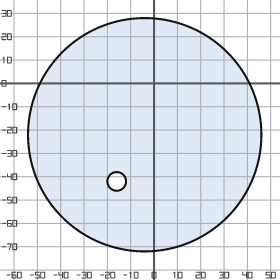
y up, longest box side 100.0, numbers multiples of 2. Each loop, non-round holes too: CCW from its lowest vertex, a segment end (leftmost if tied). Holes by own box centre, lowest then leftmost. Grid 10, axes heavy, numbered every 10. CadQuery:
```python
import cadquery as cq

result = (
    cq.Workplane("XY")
    .moveTo(-4.0, -22.0)
    .circle(50.0)
    .moveTo(-16.0, -42.0)
    .circle(4.0)
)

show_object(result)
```